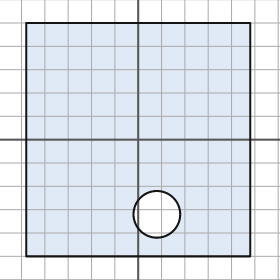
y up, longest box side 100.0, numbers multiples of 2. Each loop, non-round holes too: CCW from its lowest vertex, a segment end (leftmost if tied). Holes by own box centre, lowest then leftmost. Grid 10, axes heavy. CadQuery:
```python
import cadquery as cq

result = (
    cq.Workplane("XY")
    .moveTo(-48.0, -50.0)
    .lineTo(48.0, -50.0)
    .lineTo(48.0, 50.0)
    .lineTo(-48.0, 50.0)
    .close()
    .moveTo(8.0, -32.0)
    .circle(10.0)
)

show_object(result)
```